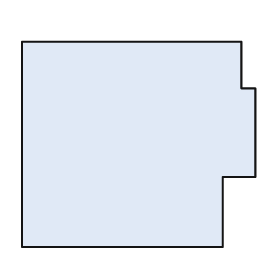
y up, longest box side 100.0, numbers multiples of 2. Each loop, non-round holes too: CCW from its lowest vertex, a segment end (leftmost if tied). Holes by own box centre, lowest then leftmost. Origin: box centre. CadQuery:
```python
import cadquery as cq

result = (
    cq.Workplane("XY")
    .moveTo(-50.0, -44.0)
    .lineTo(36.0, -44.0)
    .lineTo(36.0, -14.0)
    .lineTo(50.0, -14.0)
    .lineTo(50.0, 24.0)
    .lineTo(44.0, 24.0)
    .lineTo(44.0, 44.0)
    .lineTo(-50.0, 44.0)
    .close()
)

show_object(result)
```